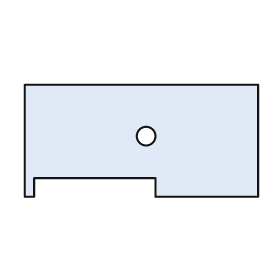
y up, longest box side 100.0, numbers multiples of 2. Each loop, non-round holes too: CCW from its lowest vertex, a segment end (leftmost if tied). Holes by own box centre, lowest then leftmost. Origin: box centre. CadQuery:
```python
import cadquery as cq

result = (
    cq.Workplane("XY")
    .moveTo(-50.0, -24.0)
    .lineTo(-46.0, -24.0)
    .lineTo(-46.0, -16.0)
    .lineTo(6.0, -16.0)
    .lineTo(6.0, -24.0)
    .lineTo(50.0, -24.0)
    .lineTo(50.0, 24.0)
    .lineTo(-50.0, 24.0)
    .close()
    .moveTo(2.0, 2.0)
    .circle(4.0)
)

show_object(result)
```